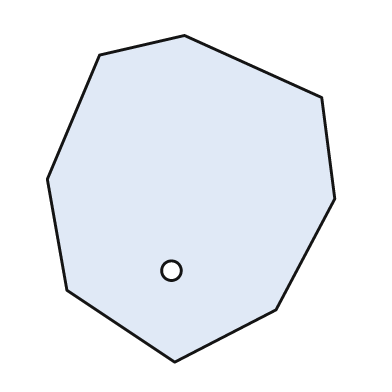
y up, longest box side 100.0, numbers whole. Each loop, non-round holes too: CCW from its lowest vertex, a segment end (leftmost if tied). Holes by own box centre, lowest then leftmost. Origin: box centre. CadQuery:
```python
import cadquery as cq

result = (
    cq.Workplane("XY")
    .moveTo(-5.0, -50.0)
    .lineTo(26.0, -34.0)
    .lineTo(44.0, 0.0)
    .lineTo(40.0, 31.0)
    .lineTo(-2.0, 50.0)
    .lineTo(-28.0, 44.0)
    .lineTo(-44.0, 6.0)
    .lineTo(-38.0, -28.0)
    .close()
    .moveTo(-6.0, -22.0)
    .circle(3.0)
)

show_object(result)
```